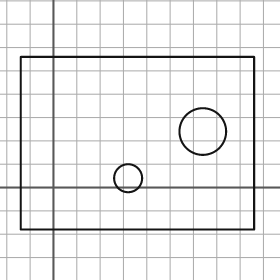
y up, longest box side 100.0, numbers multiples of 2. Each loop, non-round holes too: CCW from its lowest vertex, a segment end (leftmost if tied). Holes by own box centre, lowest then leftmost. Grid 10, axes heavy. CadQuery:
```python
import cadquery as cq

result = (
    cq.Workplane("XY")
    .moveTo(-14.0, -18.0)
    .lineTo(86.0, -18.0)
    .lineTo(86.0, 56.0)
    .lineTo(-14.0, 56.0)
    .close()
    .moveTo(32.0, 4.0)
    .circle(6.0)
    .moveTo(64.0, 24.0)
    .circle(10.0)
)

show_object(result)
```